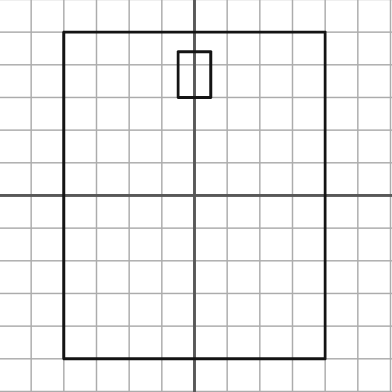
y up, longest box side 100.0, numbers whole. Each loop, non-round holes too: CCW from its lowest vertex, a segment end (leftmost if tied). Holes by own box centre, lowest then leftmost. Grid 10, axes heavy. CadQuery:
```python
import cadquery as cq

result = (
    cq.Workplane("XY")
    .moveTo(-40.0, -50.0)
    .lineTo(40.0, -50.0)
    .lineTo(40.0, 50.0)
    .lineTo(-40.0, 50.0)
    .close()
    .moveTo(-5.0, 30.0)
    .lineTo(5.0, 30.0)
    .lineTo(5.0, 44.0)
    .lineTo(-5.0, 44.0)
    .close()
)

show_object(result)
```